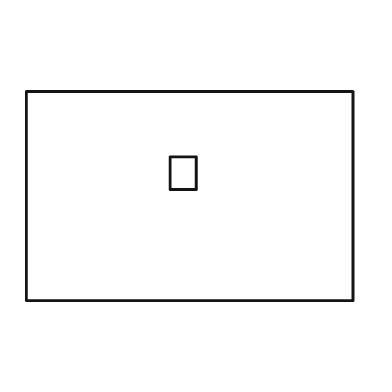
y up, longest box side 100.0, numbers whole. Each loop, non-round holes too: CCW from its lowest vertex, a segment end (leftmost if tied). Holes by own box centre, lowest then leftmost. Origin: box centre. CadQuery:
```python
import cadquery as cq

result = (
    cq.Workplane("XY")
    .moveTo(-50.0, -32.0)
    .lineTo(50.0, -32.0)
    .lineTo(50.0, 32.0)
    .lineTo(-50.0, 32.0)
    .close()
    .moveTo(-6.0, 2.0)
    .lineTo(2.0, 2.0)
    .lineTo(2.0, 12.0)
    .lineTo(-6.0, 12.0)
    .close()
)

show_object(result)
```